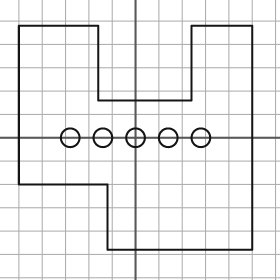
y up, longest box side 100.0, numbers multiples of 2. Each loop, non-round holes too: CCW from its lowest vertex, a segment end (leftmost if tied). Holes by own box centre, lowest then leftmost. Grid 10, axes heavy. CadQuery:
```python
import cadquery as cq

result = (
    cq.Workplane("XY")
    .moveTo(-12.0, -48.0)
    .lineTo(50.0, -48.0)
    .lineTo(50.0, 48.0)
    .lineTo(24.0, 48.0)
    .lineTo(24.0, 16.0)
    .lineTo(-16.0, 16.0)
    .lineTo(-16.0, 48.0)
    .lineTo(-50.0, 48.0)
    .lineTo(-50.0, -20.0)
    .lineTo(-12.0, -20.0)
    .close()
    .moveTo(-28.0, 0.0)
    .circle(4.0)
    .moveTo(-14.0, 0.0)
    .circle(4.0)
    .moveTo(0.0, 0.0)
    .circle(4.0)
    .moveTo(14.0, 0.0)
    .circle(4.0)
    .moveTo(28.0, 0.0)
    .circle(4.0)
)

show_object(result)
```